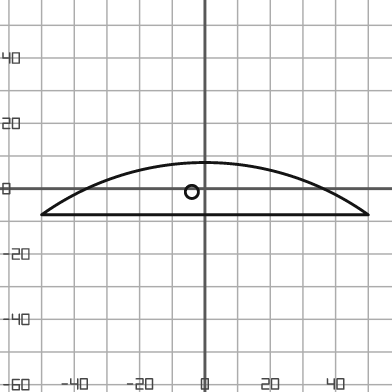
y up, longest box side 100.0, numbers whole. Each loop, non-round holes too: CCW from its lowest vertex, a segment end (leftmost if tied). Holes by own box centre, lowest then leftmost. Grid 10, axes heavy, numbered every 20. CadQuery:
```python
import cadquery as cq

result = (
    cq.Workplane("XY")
    .moveTo(-50.0, -8.0)
    .lineTo(50.0, -8.0)
    .threePointArc((0.0, 8.0), (-50.0, -8.0))
    .close()
    .moveTo(-4.0, -1.0)
    .circle(2.0)
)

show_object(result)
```